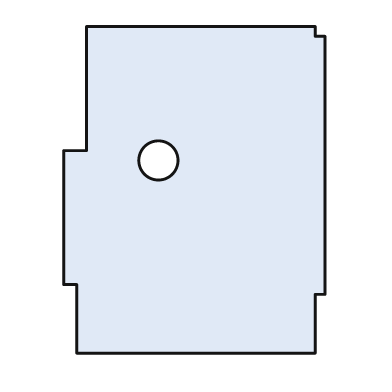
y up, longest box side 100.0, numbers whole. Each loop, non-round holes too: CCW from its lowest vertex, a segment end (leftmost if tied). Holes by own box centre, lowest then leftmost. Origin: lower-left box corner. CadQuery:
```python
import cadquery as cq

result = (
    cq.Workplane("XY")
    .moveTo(4.0, 0.0)
    .lineTo(77.0, 0.0)
    .lineTo(77.0, 18.0)
    .lineTo(80.0, 18.0)
    .lineTo(80.0, 97.0)
    .lineTo(77.0, 97.0)
    .lineTo(77.0, 100.0)
    .lineTo(7.0, 100.0)
    .lineTo(7.0, 62.0)
    .lineTo(0.0, 62.0)
    .lineTo(0.0, 21.0)
    .lineTo(4.0, 21.0)
    .close()
    .moveTo(29.0, 59.0)
    .circle(6.0)
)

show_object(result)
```